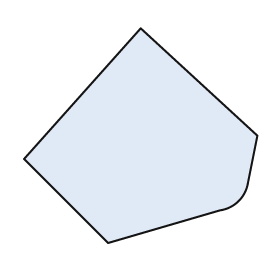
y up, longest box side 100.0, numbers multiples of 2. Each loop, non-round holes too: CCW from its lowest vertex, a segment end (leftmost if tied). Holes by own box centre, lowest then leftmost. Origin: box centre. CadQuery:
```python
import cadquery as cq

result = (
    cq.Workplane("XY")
    .moveTo(-14.0, -46.0)
    .lineTo(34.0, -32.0)
    .threePointArc((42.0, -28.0), (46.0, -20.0))
    .lineTo(50.0, 0.0)
    .lineTo(0.0, 46.0)
    .lineTo(-50.0, -10.0)
    .close()
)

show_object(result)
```